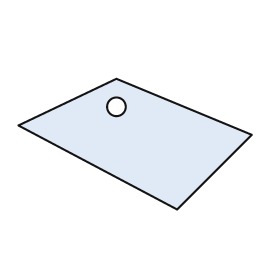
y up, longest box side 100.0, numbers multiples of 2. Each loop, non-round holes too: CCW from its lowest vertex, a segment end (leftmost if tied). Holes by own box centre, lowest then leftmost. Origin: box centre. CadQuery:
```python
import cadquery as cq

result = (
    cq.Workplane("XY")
    .moveTo(18.0, -28.0)
    .lineTo(50.0, 4.0)
    .lineTo(-8.0, 28.0)
    .lineTo(-50.0, 8.0)
    .close()
    .moveTo(-8.0, 16.0)
    .circle(4.0)
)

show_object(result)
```